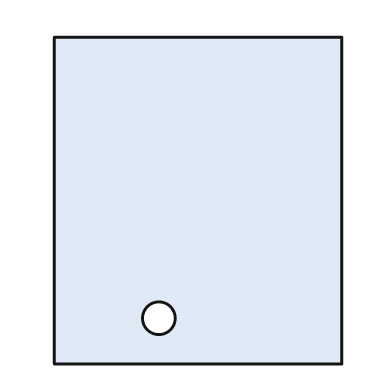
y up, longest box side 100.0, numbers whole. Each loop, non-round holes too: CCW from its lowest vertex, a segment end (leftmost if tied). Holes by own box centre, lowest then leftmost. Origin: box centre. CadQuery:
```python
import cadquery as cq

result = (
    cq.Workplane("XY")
    .moveTo(-44.0, -50.0)
    .lineTo(44.0, -50.0)
    .lineTo(44.0, 50.0)
    .lineTo(-44.0, 50.0)
    .close()
    .moveTo(-12.0, -36.0)
    .circle(5.0)
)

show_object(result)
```